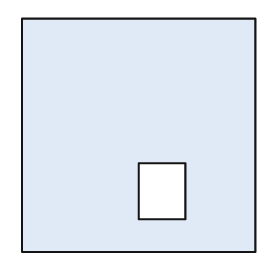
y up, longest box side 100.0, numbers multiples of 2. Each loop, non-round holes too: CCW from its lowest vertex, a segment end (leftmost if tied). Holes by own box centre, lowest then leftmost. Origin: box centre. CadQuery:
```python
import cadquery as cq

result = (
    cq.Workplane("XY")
    .moveTo(-50.0, -50.0)
    .lineTo(50.0, -50.0)
    .lineTo(50.0, 50.0)
    .lineTo(-50.0, 50.0)
    .close()
    .moveTo(0.0, -36.0)
    .lineTo(20.0, -36.0)
    .lineTo(20.0, -12.0)
    .lineTo(0.0, -12.0)
    .close()
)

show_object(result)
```